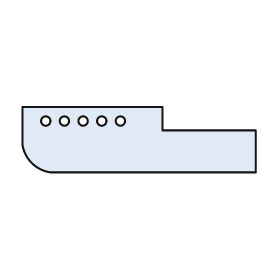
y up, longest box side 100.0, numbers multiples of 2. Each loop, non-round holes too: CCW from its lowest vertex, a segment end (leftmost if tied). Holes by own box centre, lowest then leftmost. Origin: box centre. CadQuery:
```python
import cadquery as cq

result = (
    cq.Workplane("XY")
    .moveTo(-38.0, -14.0)
    .lineTo(50.0, -14.0)
    .lineTo(50.0, 4.0)
    .lineTo(10.0, 4.0)
    .lineTo(10.0, 14.0)
    .lineTo(-50.0, 14.0)
    .lineTo(-50.0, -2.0)
    .threePointArc((-46.0, -10.0), (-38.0, -14.0))
    .close()
    .moveTo(-40.0, 8.0)
    .circle(2.0)
    .moveTo(-32.0, 8.0)
    .circle(2.0)
    .moveTo(-24.0, 8.0)
    .circle(2.0)
    .moveTo(-16.0, 8.0)
    .circle(2.0)
    .moveTo(-8.0, 8.0)
    .circle(2.0)
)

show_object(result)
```